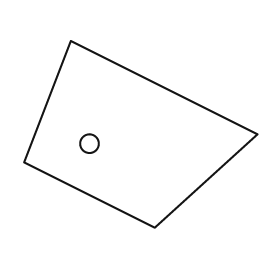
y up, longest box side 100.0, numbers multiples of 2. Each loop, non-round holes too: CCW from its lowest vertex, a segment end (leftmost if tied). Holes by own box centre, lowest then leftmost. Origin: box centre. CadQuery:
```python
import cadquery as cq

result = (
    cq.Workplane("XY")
    .moveTo(6.0, -40.0)
    .lineTo(50.0, 0.0)
    .lineTo(-30.0, 40.0)
    .lineTo(-50.0, -12.0)
    .close()
    .moveTo(-22.0, -4.0)
    .circle(4.0)
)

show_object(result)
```